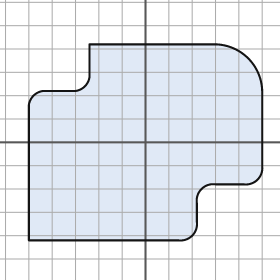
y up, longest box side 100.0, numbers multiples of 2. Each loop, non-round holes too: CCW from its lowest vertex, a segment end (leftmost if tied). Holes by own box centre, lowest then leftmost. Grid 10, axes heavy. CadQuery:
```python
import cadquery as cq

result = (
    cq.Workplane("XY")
    .moveTo(-50.0, -42.0)
    .lineTo(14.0, -42.0)
    .threePointArc((20.0, -40.0), (22.0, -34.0))
    .lineTo(22.0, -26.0)
    .threePointArc((24.0, -20.0), (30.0, -18.0))
    .lineTo(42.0, -18.0)
    .threePointArc((48.0, -16.0), (50.0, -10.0))
    .lineTo(50.0, 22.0)
    .threePointArc((44.0, 36.0), (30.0, 42.0))
    .lineTo(-24.0, 42.0)
    .lineTo(-24.0, 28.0)
    .threePointArc((-26.0, 24.0), (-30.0, 22.0))
    .lineTo(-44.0, 22.0)
    .threePointArc((-48.0, 20.0), (-50.0, 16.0))
    .close()
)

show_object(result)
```